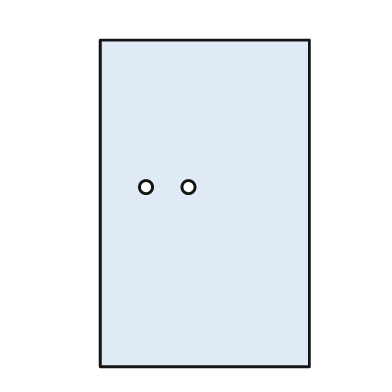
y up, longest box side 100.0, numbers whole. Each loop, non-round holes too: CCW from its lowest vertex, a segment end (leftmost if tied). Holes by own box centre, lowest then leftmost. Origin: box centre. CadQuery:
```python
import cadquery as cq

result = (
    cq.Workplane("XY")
    .moveTo(-32.0, -50.0)
    .lineTo(32.0, -50.0)
    .lineTo(32.0, 50.0)
    .lineTo(-32.0, 50.0)
    .close()
    .moveTo(-18.0, 5.0)
    .circle(2.0)
    .moveTo(-5.0, 5.0)
    .circle(2.0)
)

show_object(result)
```